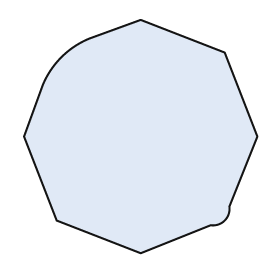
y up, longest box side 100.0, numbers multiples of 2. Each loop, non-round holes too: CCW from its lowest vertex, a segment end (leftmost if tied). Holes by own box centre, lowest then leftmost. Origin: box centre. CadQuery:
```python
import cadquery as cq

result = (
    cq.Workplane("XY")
    .moveTo(0.0, -50.0)
    .lineTo(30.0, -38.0)
    .threePointArc((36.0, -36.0), (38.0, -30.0))
    .lineTo(50.0, 0.0)
    .lineTo(36.0, 36.0)
    .lineTo(0.0, 50.0)
    .lineTo(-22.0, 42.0)
    .threePointArc((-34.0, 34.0), (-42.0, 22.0))
    .lineTo(-50.0, 0.0)
    .lineTo(-36.0, -36.0)
    .close()
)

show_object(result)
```